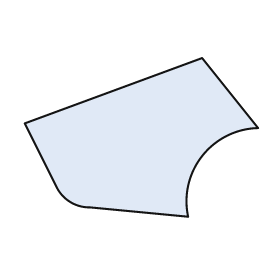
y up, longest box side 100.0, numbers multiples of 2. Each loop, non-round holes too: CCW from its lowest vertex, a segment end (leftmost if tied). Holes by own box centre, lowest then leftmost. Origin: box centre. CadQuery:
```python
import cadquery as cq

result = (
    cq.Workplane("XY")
    .moveTo(20.0, -34.0)
    .threePointArc((26.0, -8.0), (50.0, 4.0))
    .lineTo(26.0, 34.0)
    .lineTo(-50.0, 6.0)
    .lineTo(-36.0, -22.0)
    .threePointArc((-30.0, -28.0), (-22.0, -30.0))
    .close()
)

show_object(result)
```